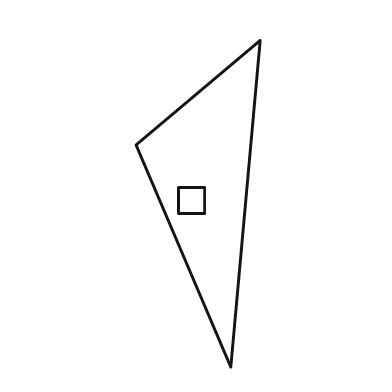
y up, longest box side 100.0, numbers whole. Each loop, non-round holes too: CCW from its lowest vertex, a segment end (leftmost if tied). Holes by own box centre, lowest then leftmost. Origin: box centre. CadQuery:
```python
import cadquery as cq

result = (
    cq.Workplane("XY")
    .moveTo(10.0, -50.0)
    .lineTo(19.0, 50.0)
    .lineTo(-19.0, 18.0)
    .close()
    .moveTo(-6.0, -3.0)
    .lineTo(2.0, -3.0)
    .lineTo(2.0, 5.0)
    .lineTo(-6.0, 5.0)
    .close()
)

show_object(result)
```